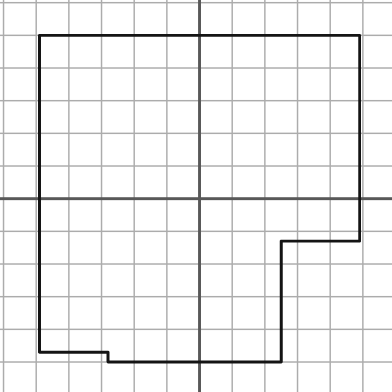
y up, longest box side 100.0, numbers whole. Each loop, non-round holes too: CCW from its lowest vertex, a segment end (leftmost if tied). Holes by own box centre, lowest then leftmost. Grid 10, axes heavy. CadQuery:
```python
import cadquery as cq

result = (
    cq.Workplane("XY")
    .moveTo(-28.0, -50.0)
    .lineTo(25.0, -50.0)
    .lineTo(25.0, -13.0)
    .lineTo(49.0, -13.0)
    .lineTo(49.0, 50.0)
    .lineTo(-49.0, 50.0)
    .lineTo(-49.0, -47.0)
    .lineTo(-28.0, -47.0)
    .close()
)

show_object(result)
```